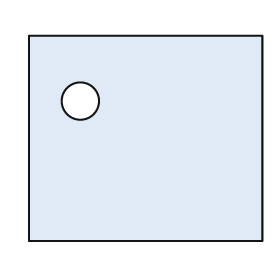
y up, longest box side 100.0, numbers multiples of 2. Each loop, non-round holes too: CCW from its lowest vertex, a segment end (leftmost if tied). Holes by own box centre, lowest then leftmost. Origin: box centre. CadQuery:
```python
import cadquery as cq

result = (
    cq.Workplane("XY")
    .moveTo(-50.0, -44.0)
    .lineTo(50.0, -44.0)
    .lineTo(50.0, 44.0)
    .lineTo(-50.0, 44.0)
    .close()
    .moveTo(-28.0, 16.0)
    .circle(8.0)
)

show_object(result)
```